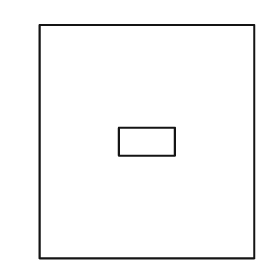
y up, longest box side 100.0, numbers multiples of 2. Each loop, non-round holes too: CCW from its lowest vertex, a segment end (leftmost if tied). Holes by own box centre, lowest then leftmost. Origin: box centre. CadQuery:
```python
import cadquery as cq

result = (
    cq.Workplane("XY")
    .moveTo(-46.0, -50.0)
    .lineTo(46.0, -50.0)
    .lineTo(46.0, 50.0)
    .lineTo(-46.0, 50.0)
    .close()
    .moveTo(-12.0, -6.0)
    .lineTo(12.0, -6.0)
    .lineTo(12.0, 6.0)
    .lineTo(-12.0, 6.0)
    .close()
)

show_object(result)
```